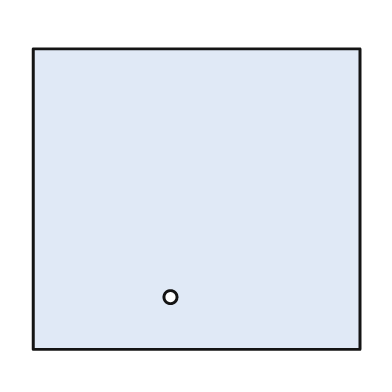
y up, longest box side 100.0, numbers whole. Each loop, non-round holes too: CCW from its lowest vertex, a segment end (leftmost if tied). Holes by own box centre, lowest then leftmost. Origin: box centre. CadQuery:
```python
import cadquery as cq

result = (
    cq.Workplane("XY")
    .moveTo(-50.0, -46.0)
    .lineTo(50.0, -46.0)
    .lineTo(50.0, 46.0)
    .lineTo(-50.0, 46.0)
    .close()
    .moveTo(-8.0, -30.0)
    .circle(2.0)
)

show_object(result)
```